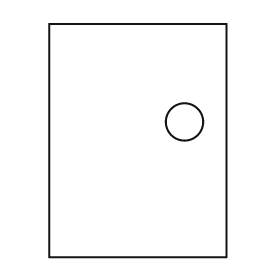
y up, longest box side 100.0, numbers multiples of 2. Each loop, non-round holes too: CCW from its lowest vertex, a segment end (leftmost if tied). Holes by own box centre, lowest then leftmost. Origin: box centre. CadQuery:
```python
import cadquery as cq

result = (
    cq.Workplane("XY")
    .moveTo(-38.0, -50.0)
    .lineTo(38.0, -50.0)
    .lineTo(38.0, 50.0)
    .lineTo(-38.0, 50.0)
    .close()
    .moveTo(20.0, 8.0)
    .circle(8.0)
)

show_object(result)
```